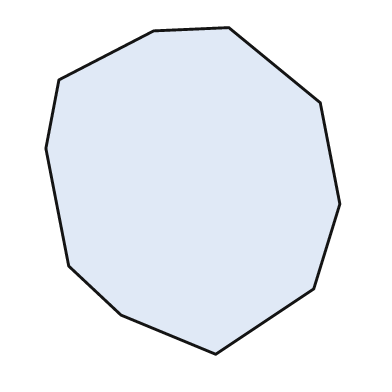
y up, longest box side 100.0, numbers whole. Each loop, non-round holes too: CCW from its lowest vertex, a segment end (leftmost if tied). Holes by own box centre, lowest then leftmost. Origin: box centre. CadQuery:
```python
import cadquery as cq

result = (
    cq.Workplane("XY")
    .moveTo(7.0, -50.0)
    .lineTo(37.0, -30.0)
    .lineTo(45.0, -4.0)
    .lineTo(39.0, 27.0)
    .lineTo(11.0, 50.0)
    .lineTo(-12.0, 49.0)
    .lineTo(-41.0, 34.0)
    .lineTo(-45.0, 13.0)
    .lineTo(-38.0, -23.0)
    .lineTo(-22.0, -38.0)
    .close()
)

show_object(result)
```